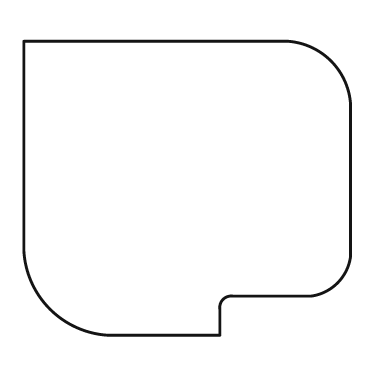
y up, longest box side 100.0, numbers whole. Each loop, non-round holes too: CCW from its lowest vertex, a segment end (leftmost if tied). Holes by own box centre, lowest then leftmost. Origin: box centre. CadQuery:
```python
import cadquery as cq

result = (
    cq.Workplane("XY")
    .moveTo(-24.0, -45.0)
    .lineTo(10.0, -45.0)
    .lineTo(10.0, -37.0)
    .threePointArc((11.0, -34.0), (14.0, -33.0))
    .lineTo(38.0, -33.0)
    .threePointArc((46.0, -29.0), (50.0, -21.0))
    .lineTo(50.0, 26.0)
    .threePointArc((44.0, 39.0), (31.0, 45.0))
    .lineTo(-50.0, 45.0)
    .lineTo(-50.0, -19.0)
    .threePointArc((-42.0, -37.0), (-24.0, -45.0))
    .close()
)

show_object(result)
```